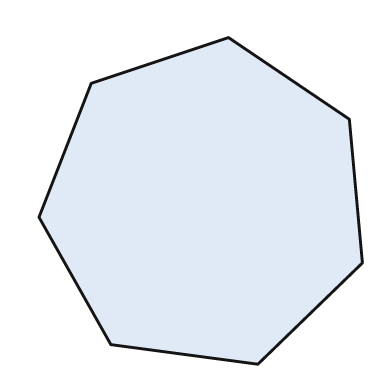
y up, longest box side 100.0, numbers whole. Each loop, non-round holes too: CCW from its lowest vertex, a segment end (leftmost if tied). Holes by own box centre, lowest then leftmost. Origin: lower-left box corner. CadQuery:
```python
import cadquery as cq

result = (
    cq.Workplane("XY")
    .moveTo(67.0, 0.0)
    .lineTo(99.0, 31.0)
    .lineTo(95.0, 75.0)
    .lineTo(58.0, 100.0)
    .lineTo(16.0, 86.0)
    .lineTo(0.0, 45.0)
    .lineTo(22.0, 6.0)
    .close()
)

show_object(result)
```